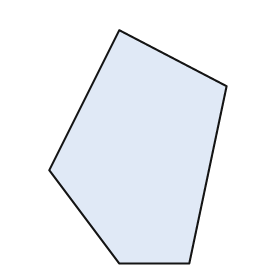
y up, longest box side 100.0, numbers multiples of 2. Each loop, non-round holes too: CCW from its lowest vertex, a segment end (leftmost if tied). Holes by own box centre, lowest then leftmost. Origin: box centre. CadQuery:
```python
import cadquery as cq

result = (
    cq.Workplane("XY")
    .moveTo(-8.0, -50.0)
    .lineTo(22.0, -50.0)
    .lineTo(38.0, 26.0)
    .lineTo(-8.0, 50.0)
    .lineTo(-38.0, -10.0)
    .close()
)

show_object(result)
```